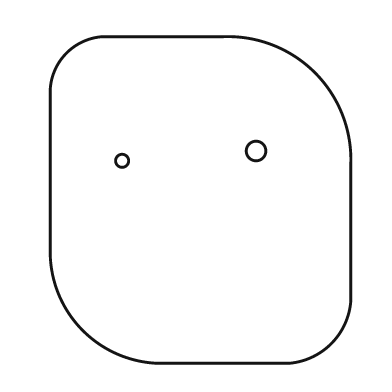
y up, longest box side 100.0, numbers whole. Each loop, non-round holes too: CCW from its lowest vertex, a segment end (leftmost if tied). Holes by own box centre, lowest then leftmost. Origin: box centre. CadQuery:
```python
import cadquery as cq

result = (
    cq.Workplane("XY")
    .moveTo(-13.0, -50.0)
    .lineTo(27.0, -50.0)
    .threePointArc((40.0, -44.0), (46.0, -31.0))
    .lineTo(46.0, 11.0)
    .threePointArc((35.0, 39.0), (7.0, 50.0))
    .lineTo(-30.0, 50.0)
    .threePointArc((-41.0, 45.0), (-46.0, 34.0))
    .lineTo(-46.0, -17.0)
    .threePointArc((-36.0, -40.0), (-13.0, -50.0))
    .close()
    .moveTo(-24.0, 12.0)
    .circle(2.0)
    .moveTo(17.0, 15.0)
    .circle(3.0)
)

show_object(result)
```